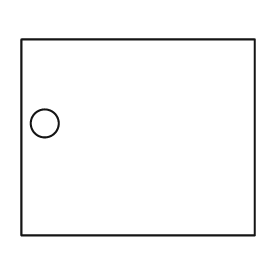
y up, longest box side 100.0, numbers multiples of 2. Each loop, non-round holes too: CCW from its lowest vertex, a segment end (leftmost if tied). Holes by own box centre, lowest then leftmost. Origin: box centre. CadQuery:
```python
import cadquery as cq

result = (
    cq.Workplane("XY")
    .moveTo(-50.0, -42.0)
    .lineTo(50.0, -42.0)
    .lineTo(50.0, 42.0)
    .lineTo(-50.0, 42.0)
    .close()
    .moveTo(-40.0, 6.0)
    .circle(6.0)
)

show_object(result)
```